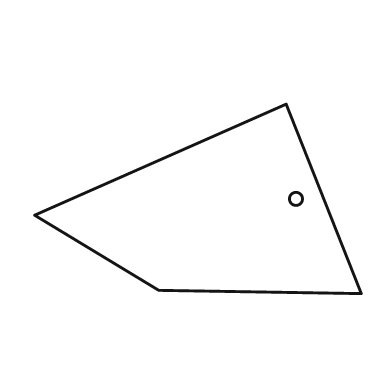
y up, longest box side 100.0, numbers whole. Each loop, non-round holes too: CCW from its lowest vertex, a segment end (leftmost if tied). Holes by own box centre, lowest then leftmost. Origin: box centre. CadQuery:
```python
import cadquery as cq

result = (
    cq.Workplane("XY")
    .moveTo(50.0, -29.0)
    .lineTo(27.0, 29.0)
    .lineTo(-50.0, -5.0)
    .lineTo(-12.0, -28.0)
    .close()
    .moveTo(30.0, 0.0)
    .circle(2.0)
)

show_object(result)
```